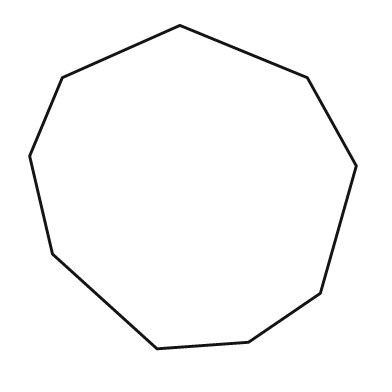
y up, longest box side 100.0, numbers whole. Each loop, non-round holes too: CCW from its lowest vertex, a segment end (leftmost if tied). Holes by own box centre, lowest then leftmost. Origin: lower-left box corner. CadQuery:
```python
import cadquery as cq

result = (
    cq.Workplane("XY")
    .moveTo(39.0, 0.0)
    .lineTo(67.0, 2.0)
    .lineTo(89.0, 17.0)
    .lineTo(100.0, 56.0)
    .lineTo(85.0, 83.0)
    .lineTo(46.0, 99.0)
    .lineTo(10.0, 83.0)
    .lineTo(0.0, 59.0)
    .lineTo(7.0, 29.0)
    .close()
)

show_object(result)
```